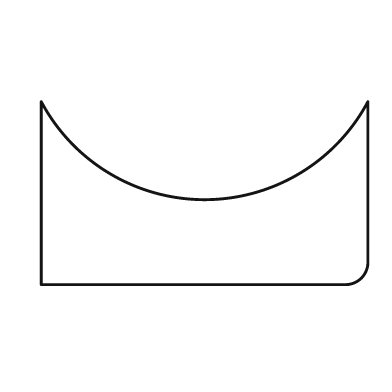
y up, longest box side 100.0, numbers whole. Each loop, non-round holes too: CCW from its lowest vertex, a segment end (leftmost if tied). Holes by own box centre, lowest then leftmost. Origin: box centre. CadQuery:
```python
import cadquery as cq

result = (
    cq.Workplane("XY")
    .moveTo(-50.0, -28.0)
    .lineTo(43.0, -28.0)
    .threePointArc((48.0, -26.0), (50.0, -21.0))
    .lineTo(50.0, 28.0)
    .threePointArc((0.0, -2.0), (-50.0, 28.0))
    .close()
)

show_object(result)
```